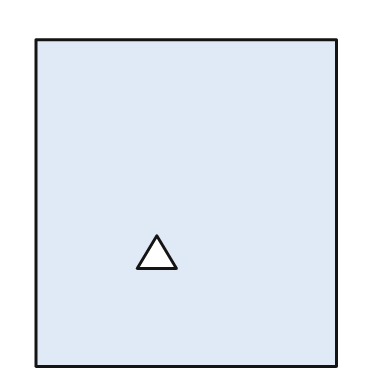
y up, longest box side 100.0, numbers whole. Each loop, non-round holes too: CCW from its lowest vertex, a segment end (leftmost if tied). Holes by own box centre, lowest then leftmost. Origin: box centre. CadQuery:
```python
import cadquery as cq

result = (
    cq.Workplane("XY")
    .moveTo(-46.0, -50.0)
    .lineTo(46.0, -50.0)
    .lineTo(46.0, 50.0)
    .lineTo(-46.0, 50.0)
    .close()
    .moveTo(-15.0, -20.0)
    .lineTo(-3.0, -20.0)
    .lineTo(-9.0, -10.0)
    .close()
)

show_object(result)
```